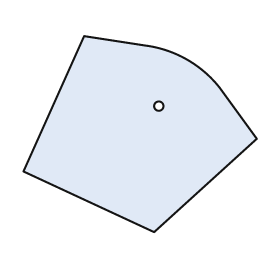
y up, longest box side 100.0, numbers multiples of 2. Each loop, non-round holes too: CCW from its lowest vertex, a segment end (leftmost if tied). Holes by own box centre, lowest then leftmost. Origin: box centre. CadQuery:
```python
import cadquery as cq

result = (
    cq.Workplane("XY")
    .moveTo(6.0, -42.0)
    .lineTo(50.0, -2.0)
    .lineTo(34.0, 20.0)
    .threePointArc((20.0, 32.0), (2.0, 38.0))
    .lineTo(-24.0, 42.0)
    .lineTo(-50.0, -16.0)
    .close()
    .moveTo(8.0, 12.0)
    .circle(2.0)
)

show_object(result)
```